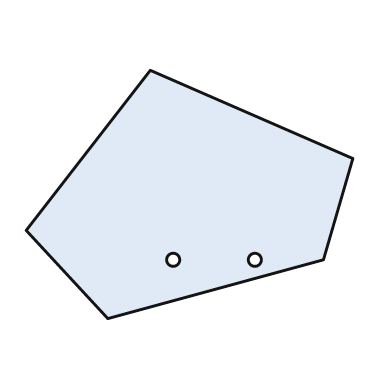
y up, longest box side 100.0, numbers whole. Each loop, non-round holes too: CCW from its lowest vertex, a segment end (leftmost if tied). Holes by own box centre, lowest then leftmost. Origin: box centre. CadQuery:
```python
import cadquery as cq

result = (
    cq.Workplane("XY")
    .moveTo(-25.0, -38.0)
    .lineTo(41.0, -20.0)
    .lineTo(50.0, 11.0)
    .lineTo(-12.0, 38.0)
    .lineTo(-50.0, -11.0)
    .close()
    .moveTo(-5.0, -20.0)
    .circle(2.0)
    .moveTo(20.0, -20.0)
    .circle(2.0)
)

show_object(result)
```